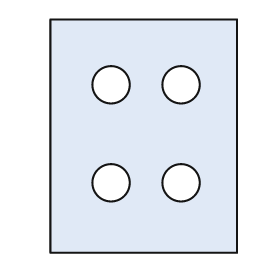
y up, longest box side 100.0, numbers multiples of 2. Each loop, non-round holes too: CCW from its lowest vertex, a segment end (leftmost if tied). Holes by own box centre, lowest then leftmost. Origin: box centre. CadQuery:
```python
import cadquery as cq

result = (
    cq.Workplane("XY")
    .moveTo(-40.0, -50.0)
    .lineTo(40.0, -50.0)
    .lineTo(40.0, 50.0)
    .lineTo(-40.0, 50.0)
    .close()
    .moveTo(-14.0, -20.0)
    .circle(8.0)
    .moveTo(16.0, -20.0)
    .circle(8.0)
    .moveTo(-14.0, 22.0)
    .circle(8.0)
    .moveTo(16.0, 22.0)
    .circle(8.0)
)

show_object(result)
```